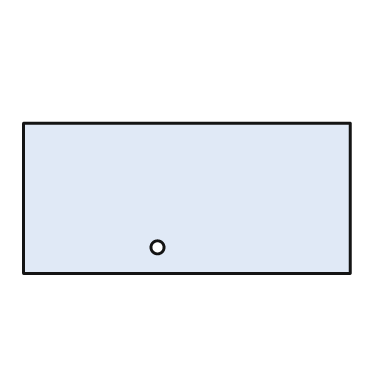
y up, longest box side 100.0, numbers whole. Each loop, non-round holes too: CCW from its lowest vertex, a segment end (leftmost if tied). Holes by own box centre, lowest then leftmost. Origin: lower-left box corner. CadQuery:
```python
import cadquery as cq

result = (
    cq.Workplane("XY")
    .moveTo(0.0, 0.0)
    .lineTo(100.0, 0.0)
    .lineTo(100.0, 46.0)
    .lineTo(0.0, 46.0)
    .close()
    .moveTo(41.0, 8.0)
    .circle(2.0)
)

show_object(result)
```